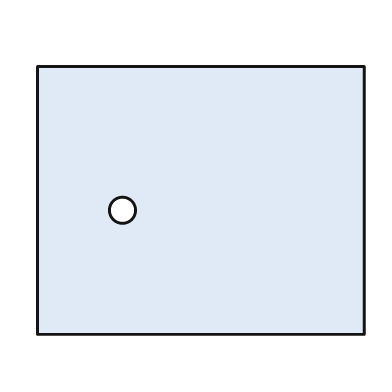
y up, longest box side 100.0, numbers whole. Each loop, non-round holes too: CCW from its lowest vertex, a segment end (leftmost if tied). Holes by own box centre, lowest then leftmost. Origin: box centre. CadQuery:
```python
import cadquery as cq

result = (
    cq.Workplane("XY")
    .moveTo(-50.0, -41.0)
    .lineTo(50.0, -41.0)
    .lineTo(50.0, 41.0)
    .lineTo(-50.0, 41.0)
    .close()
    .moveTo(-24.0, -3.0)
    .circle(4.0)
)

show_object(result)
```